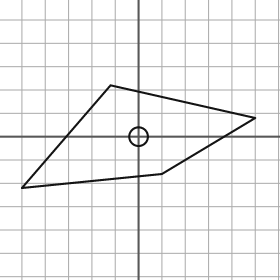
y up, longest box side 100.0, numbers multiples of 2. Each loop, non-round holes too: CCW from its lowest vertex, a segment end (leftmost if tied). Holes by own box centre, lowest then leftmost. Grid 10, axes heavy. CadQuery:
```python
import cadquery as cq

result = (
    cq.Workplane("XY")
    .moveTo(-50.0, -22.0)
    .lineTo(10.0, -16.0)
    .lineTo(50.0, 8.0)
    .lineTo(-12.0, 22.0)
    .close()
    .moveTo(0.0, 0.0)
    .circle(4.0)
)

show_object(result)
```